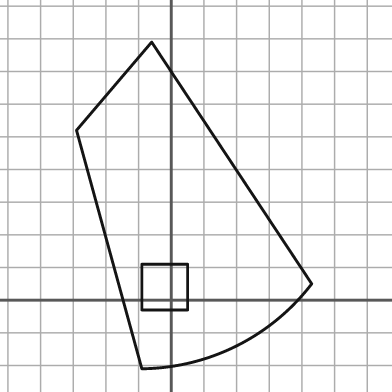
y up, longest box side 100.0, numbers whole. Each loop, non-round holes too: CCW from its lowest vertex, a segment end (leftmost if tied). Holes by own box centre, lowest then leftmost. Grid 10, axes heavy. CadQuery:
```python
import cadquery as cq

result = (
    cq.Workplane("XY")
    .moveTo(-9.0, -21.0)
    .threePointArc((20.0, -14.0), (43.0, 5.0))
    .lineTo(-6.0, 79.0)
    .lineTo(-29.0, 52.0)
    .close()
    .moveTo(-9.0, -3.0)
    .lineTo(5.0, -3.0)
    .lineTo(5.0, 11.0)
    .lineTo(-9.0, 11.0)
    .close()
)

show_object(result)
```